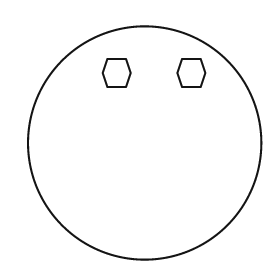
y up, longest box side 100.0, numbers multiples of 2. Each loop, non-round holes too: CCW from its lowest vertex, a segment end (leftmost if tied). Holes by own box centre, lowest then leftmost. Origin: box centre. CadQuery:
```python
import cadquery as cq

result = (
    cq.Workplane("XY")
    .moveTo(0.0, 0.0)
    .circle(50.0)
    .moveTo(-16.0, 24.0)
    .lineTo(-8.0, 24.0)
    .lineTo(-6.0, 30.0)
    .lineTo(-8.0, 36.0)
    .lineTo(-16.0, 36.0)
    .lineTo(-18.0, 30.0)
    .close()
    .moveTo(16.0, 24.0)
    .lineTo(24.0, 24.0)
    .lineTo(26.0, 30.0)
    .lineTo(24.0, 36.0)
    .lineTo(16.0, 36.0)
    .lineTo(14.0, 30.0)
    .close()
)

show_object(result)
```